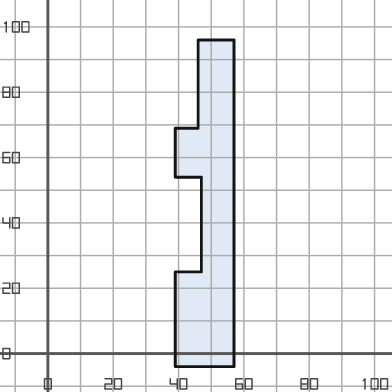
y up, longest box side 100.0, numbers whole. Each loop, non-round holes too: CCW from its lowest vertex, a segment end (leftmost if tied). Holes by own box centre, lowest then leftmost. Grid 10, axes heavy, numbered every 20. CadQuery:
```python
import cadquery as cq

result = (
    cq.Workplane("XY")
    .moveTo(39.0, -4.0)
    .lineTo(57.0, -4.0)
    .lineTo(57.0, 96.0)
    .lineTo(46.0, 96.0)
    .lineTo(46.0, 69.0)
    .lineTo(39.0, 69.0)
    .lineTo(39.0, 54.0)
    .lineTo(47.0, 54.0)
    .lineTo(47.0, 25.0)
    .lineTo(39.0, 25.0)
    .close()
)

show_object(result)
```